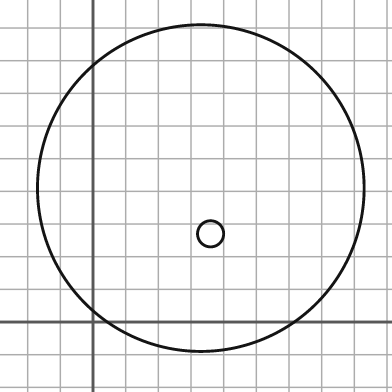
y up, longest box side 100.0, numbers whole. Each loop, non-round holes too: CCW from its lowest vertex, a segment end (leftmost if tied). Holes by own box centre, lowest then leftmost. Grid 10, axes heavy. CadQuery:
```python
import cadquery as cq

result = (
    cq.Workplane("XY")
    .moveTo(33.0, 41.0)
    .circle(50.0)
    .moveTo(36.0, 27.0)
    .circle(4.0)
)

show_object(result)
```